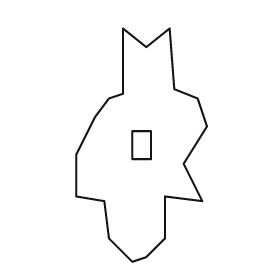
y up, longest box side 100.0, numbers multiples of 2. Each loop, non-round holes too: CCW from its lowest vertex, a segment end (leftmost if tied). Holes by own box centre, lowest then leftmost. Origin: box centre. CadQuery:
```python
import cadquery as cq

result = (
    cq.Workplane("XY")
    .moveTo(-4.0, -50.0)
    .lineTo(2.0, -48.0)
    .lineTo(10.0, -40.0)
    .lineTo(10.0, -22.0)
    .lineTo(26.0, -24.0)
    .lineTo(18.0, -8.0)
    .lineTo(28.0, 8.0)
    .lineTo(24.0, 20.0)
    .lineTo(14.0, 24.0)
    .lineTo(12.0, 50.0)
    .lineTo(2.0, 42.0)
    .lineTo(-8.0, 50.0)
    .lineTo(-8.0, 22.0)
    .lineTo(-14.0, 20.0)
    .lineTo(-20.0, 12.0)
    .lineTo(-28.0, -4.0)
    .lineTo(-28.0, -22.0)
    .lineTo(-16.0, -24.0)
    .lineTo(-14.0, -40.0)
    .close()
    .moveTo(-4.0, -6.0)
    .lineTo(4.0, -6.0)
    .lineTo(4.0, 6.0)
    .lineTo(-4.0, 6.0)
    .close()
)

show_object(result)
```